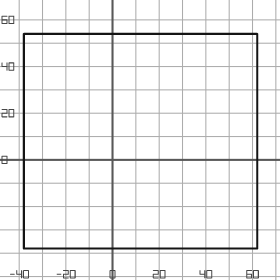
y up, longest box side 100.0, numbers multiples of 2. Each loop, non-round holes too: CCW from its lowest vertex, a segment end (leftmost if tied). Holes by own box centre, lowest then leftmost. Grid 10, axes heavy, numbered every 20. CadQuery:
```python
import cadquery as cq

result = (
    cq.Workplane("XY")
    .moveTo(-38.0, -38.0)
    .lineTo(62.0, -38.0)
    .lineTo(62.0, 54.0)
    .lineTo(-38.0, 54.0)
    .close()
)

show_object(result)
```